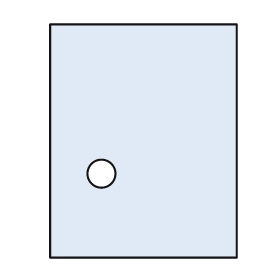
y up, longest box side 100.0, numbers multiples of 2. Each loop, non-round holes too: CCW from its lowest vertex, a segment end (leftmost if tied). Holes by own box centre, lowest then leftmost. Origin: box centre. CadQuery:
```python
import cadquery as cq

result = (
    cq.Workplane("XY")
    .moveTo(-40.0, -50.0)
    .lineTo(40.0, -50.0)
    .lineTo(40.0, 50.0)
    .lineTo(-40.0, 50.0)
    .close()
    .moveTo(-18.0, -14.0)
    .circle(6.0)
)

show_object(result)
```